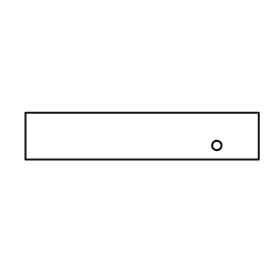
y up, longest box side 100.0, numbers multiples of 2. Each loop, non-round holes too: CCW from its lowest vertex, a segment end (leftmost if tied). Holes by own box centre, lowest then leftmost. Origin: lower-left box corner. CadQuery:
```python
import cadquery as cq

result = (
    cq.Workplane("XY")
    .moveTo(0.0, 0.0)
    .lineTo(100.0, 0.0)
    .lineTo(100.0, 20.0)
    .lineTo(0.0, 20.0)
    .close()
    .moveTo(82.0, 6.0)
    .circle(2.0)
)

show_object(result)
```